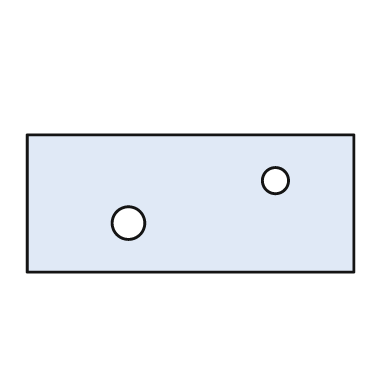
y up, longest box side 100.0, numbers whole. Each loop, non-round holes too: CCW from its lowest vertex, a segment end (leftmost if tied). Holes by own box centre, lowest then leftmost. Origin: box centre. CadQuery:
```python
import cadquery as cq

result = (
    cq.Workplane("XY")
    .moveTo(-50.0, -21.0)
    .lineTo(50.0, -21.0)
    .lineTo(50.0, 21.0)
    .lineTo(-50.0, 21.0)
    .close()
    .moveTo(-19.0, -6.0)
    .circle(5.0)
    .moveTo(26.0, 7.0)
    .circle(4.0)
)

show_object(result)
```